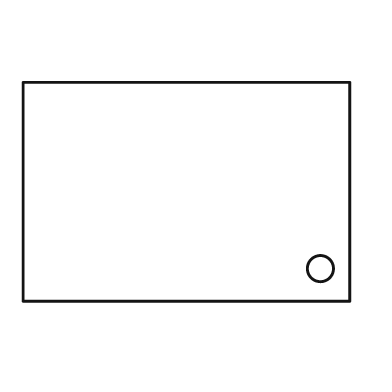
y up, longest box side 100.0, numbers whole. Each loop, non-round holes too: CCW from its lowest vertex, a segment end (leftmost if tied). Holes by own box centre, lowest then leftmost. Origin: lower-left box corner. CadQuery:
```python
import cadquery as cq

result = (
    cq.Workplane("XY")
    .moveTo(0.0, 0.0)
    .lineTo(100.0, 0.0)
    .lineTo(100.0, 67.0)
    .lineTo(0.0, 67.0)
    .close()
    .moveTo(91.0, 10.0)
    .circle(4.0)
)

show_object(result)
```